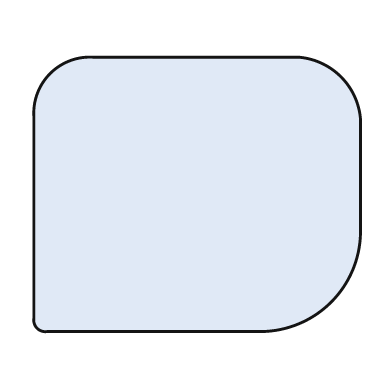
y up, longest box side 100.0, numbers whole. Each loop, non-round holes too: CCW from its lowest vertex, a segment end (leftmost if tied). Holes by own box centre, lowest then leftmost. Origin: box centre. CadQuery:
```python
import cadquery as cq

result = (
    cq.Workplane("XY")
    .moveTo(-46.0, -42.0)
    .lineTo(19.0, -42.0)
    .threePointArc((41.0, -33.0), (50.0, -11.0))
    .lineTo(50.0, 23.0)
    .threePointArc((44.0, 36.0), (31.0, 42.0))
    .lineTo(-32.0, 42.0)
    .threePointArc((-45.0, 37.0), (-50.0, 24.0))
    .lineTo(-50.0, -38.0)
    .threePointArc((-49.0, -41.0), (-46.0, -42.0))
    .close()
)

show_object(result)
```